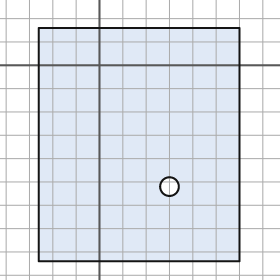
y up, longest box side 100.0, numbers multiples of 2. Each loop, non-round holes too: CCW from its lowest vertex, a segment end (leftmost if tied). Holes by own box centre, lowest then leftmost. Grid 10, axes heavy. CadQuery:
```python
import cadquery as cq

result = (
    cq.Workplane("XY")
    .moveTo(-26.0, -84.0)
    .lineTo(60.0, -84.0)
    .lineTo(60.0, 16.0)
    .lineTo(-26.0, 16.0)
    .close()
    .moveTo(30.0, -52.0)
    .circle(4.0)
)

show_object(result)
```